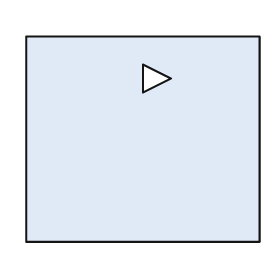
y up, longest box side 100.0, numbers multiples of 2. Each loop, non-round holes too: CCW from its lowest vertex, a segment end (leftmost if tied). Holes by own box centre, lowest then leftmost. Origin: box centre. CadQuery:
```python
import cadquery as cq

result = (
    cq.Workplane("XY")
    .moveTo(-50.0, -44.0)
    .lineTo(50.0, -44.0)
    .lineTo(50.0, 44.0)
    .lineTo(-50.0, 44.0)
    .close()
    .moveTo(0.0, 20.0)
    .lineTo(12.0, 26.0)
    .lineTo(0.0, 32.0)
    .close()
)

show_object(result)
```